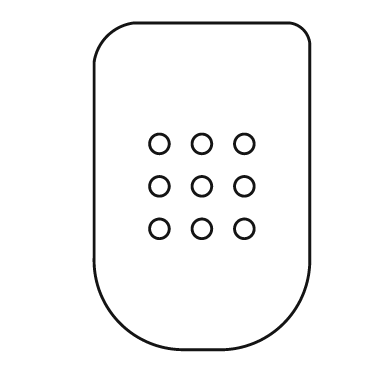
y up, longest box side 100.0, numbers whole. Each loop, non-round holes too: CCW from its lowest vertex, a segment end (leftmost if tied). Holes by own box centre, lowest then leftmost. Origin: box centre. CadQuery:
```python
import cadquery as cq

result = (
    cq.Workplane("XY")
    .moveTo(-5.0, -50.0)
    .lineTo(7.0, -50.0)
    .threePointArc((25.0, -42.0), (33.0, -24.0))
    .lineTo(33.0, 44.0)
    .threePointArc((31.0, 48.0), (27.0, 50.0))
    .lineTo(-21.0, 50.0)
    .threePointArc((-29.0, 46.0), (-33.0, 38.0))
    .lineTo(-33.0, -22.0)
    .threePointArc((-25.0, -42.0), (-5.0, -50.0))
    .close()
    .moveTo(-13.0, -13.0)
    .circle(3.0)
    .moveTo(0.0, -13.0)
    .circle(3.0)
    .moveTo(13.0, -13.0)
    .circle(3.0)
    .moveTo(-13.0, 0.0)
    .circle(3.0)
    .moveTo(0.0, 0.0)
    .circle(3.0)
    .moveTo(13.0, 0.0)
    .circle(3.0)
    .moveTo(-13.0, 13.0)
    .circle(3.0)
    .moveTo(0.0, 13.0)
    .circle(3.0)
    .moveTo(13.0, 13.0)
    .circle(3.0)
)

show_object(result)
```